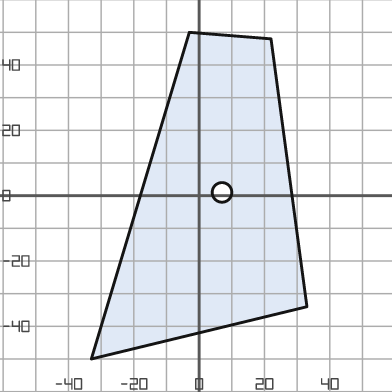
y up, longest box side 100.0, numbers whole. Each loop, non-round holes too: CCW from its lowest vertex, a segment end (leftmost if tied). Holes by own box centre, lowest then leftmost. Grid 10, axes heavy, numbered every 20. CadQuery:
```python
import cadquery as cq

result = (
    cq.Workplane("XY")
    .moveTo(-33.0, -50.0)
    .lineTo(33.0, -34.0)
    .lineTo(22.0, 48.0)
    .lineTo(-3.0, 50.0)
    .close()
    .moveTo(7.0, 1.0)
    .circle(3.0)
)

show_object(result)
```